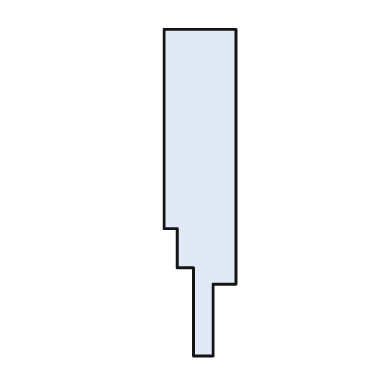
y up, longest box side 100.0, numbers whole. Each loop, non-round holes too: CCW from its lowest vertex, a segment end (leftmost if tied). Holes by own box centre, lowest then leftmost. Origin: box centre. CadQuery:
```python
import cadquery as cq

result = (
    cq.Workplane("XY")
    .moveTo(-2.0, -50.0)
    .lineTo(4.0, -50.0)
    .lineTo(4.0, -28.0)
    .lineTo(11.0, -28.0)
    .lineTo(11.0, 50.0)
    .lineTo(-11.0, 50.0)
    .lineTo(-11.0, -11.0)
    .lineTo(-7.0, -11.0)
    .lineTo(-7.0, -23.0)
    .lineTo(-2.0, -23.0)
    .close()
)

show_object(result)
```